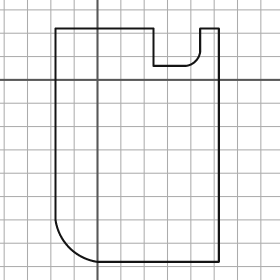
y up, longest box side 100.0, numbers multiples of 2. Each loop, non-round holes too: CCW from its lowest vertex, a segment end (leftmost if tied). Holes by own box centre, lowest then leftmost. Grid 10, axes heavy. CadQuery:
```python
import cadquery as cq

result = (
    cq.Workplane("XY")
    .moveTo(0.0, -78.0)
    .lineTo(52.0, -78.0)
    .lineTo(52.0, 22.0)
    .lineTo(44.0, 22.0)
    .lineTo(44.0, 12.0)
    .threePointArc((42.0, 8.0), (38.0, 6.0))
    .lineTo(24.0, 6.0)
    .lineTo(24.0, 22.0)
    .lineTo(-18.0, 22.0)
    .lineTo(-18.0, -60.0)
    .threePointArc((-12.0, -72.0), (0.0, -78.0))
    .close()
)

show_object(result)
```